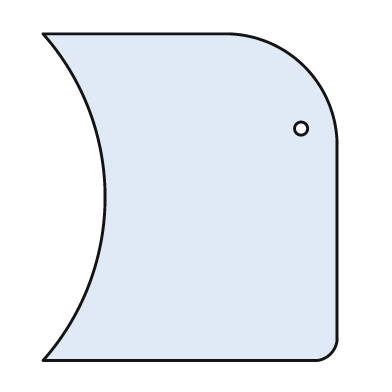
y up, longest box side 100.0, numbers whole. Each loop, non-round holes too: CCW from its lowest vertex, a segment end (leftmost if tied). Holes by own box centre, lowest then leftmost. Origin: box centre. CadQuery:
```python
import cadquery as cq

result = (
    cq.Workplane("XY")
    .moveTo(-45.0, -50.0)
    .lineTo(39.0, -50.0)
    .threePointArc((43.0, -48.0), (45.0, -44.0))
    .lineTo(45.0, 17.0)
    .threePointArc((35.0, 40.0), (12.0, 50.0))
    .lineTo(-45.0, 50.0)
    .threePointArc((-26.0, 0.0), (-45.0, -50.0))
    .close()
    .moveTo(34.0, 21.0)
    .circle(2.0)
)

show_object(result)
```